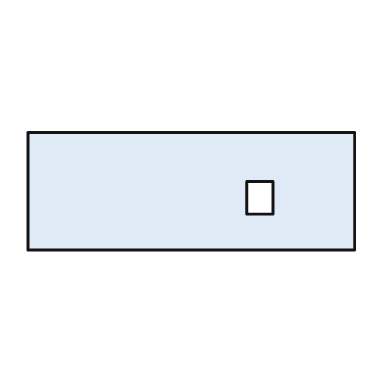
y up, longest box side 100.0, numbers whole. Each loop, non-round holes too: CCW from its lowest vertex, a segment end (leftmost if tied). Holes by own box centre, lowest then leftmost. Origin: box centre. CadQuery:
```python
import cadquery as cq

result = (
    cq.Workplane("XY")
    .moveTo(-50.0, -18.0)
    .lineTo(50.0, -18.0)
    .lineTo(50.0, 18.0)
    .lineTo(-50.0, 18.0)
    .close()
    .moveTo(17.0, -7.0)
    .lineTo(25.0, -7.0)
    .lineTo(25.0, 3.0)
    .lineTo(17.0, 3.0)
    .close()
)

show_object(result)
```